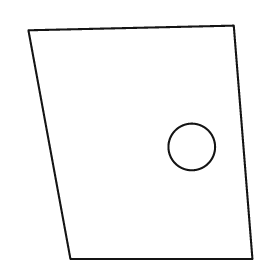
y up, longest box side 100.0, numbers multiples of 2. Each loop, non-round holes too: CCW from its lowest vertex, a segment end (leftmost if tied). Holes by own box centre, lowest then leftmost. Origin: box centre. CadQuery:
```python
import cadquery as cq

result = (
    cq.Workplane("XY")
    .moveTo(-30.0, -50.0)
    .lineTo(48.0, -50.0)
    .lineTo(40.0, 50.0)
    .lineTo(-48.0, 48.0)
    .close()
    .moveTo(22.0, -2.0)
    .circle(10.0)
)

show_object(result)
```